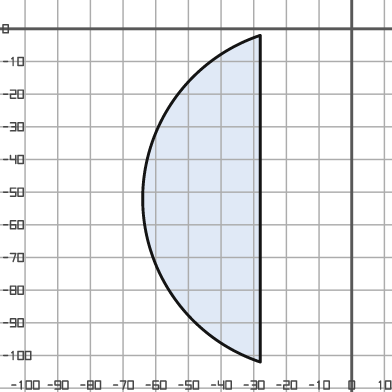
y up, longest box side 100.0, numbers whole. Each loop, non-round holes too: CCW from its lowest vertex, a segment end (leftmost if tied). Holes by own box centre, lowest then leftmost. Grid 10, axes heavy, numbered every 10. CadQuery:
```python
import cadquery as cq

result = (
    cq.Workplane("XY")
    .moveTo(-28.0, -102.0)
    .lineTo(-28.0, -2.0)
    .threePointArc((-64.0, -52.0), (-28.0, -102.0))
    .close()
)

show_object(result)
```